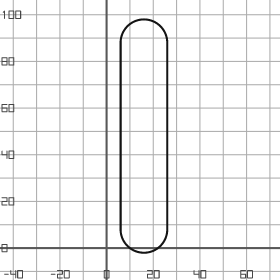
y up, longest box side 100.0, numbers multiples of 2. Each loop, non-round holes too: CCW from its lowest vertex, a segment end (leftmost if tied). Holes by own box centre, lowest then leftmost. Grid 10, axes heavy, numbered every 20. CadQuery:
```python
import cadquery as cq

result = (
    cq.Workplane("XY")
    .moveTo(6.0, 8.0)
    .threePointArc((16.0, -2.0), (26.0, 8.0))
    .lineTo(26.0, 88.0)
    .threePointArc((16.0, 98.0), (6.0, 88.0))
    .close()
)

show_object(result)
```